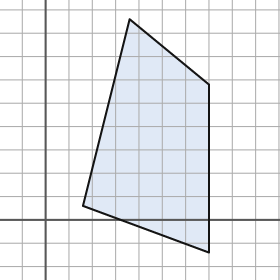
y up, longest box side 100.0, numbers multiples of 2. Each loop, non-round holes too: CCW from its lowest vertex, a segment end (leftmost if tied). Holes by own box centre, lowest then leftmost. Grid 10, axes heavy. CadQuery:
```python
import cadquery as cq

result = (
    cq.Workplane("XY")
    .moveTo(70.0, -14.0)
    .lineTo(70.0, 58.0)
    .lineTo(36.0, 86.0)
    .lineTo(16.0, 6.0)
    .close()
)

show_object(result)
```